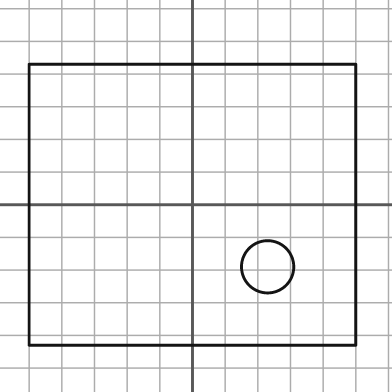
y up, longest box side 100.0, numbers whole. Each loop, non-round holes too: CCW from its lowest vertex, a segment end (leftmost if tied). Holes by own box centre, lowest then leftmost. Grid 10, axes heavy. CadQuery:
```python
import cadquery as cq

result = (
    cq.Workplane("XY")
    .moveTo(-50.0, -43.0)
    .lineTo(50.0, -43.0)
    .lineTo(50.0, 43.0)
    .lineTo(-50.0, 43.0)
    .close()
    .moveTo(23.0, -19.0)
    .circle(8.0)
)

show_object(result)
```